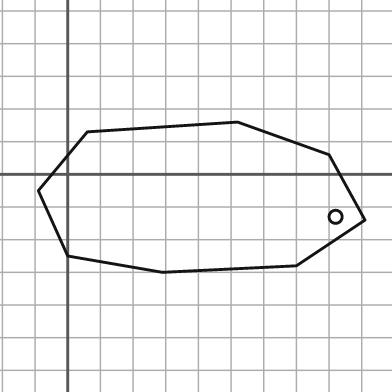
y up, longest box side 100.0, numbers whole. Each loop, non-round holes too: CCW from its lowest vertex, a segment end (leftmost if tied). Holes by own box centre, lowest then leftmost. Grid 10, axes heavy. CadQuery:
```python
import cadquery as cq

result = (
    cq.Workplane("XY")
    .moveTo(29.0, -30.0)
    .lineTo(70.0, -28.0)
    .lineTo(91.0, -14.0)
    .lineTo(80.0, 6.0)
    .lineTo(52.0, 16.0)
    .lineTo(6.0, 13.0)
    .lineTo(-9.0, -5.0)
    .lineTo(0.0, -25.0)
    .close()
    .moveTo(82.0, -13.0)
    .circle(2.0)
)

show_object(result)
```